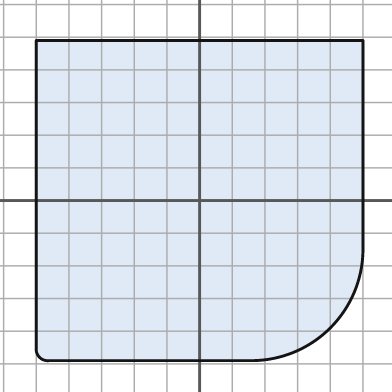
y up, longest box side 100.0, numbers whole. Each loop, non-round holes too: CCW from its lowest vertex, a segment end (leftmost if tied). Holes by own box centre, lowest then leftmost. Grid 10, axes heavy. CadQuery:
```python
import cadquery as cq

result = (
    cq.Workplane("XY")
    .moveTo(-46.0, -49.0)
    .lineTo(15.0, -49.0)
    .threePointArc((40.0, -39.0), (50.0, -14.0))
    .lineTo(50.0, 49.0)
    .lineTo(-50.0, 49.0)
    .lineTo(-50.0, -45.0)
    .threePointArc((-49.0, -48.0), (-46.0, -49.0))
    .close()
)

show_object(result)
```